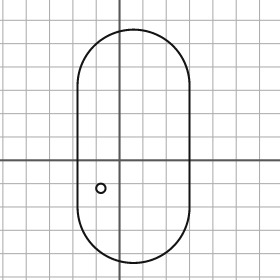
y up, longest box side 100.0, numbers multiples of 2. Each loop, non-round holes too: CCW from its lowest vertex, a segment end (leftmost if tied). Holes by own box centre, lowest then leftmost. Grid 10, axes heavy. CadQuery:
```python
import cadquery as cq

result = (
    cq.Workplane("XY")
    .moveTo(-18.0, -20.0)
    .threePointArc((6.0, -44.0), (30.0, -20.0))
    .lineTo(30.0, 32.0)
    .threePointArc((6.0, 56.0), (-18.0, 32.0))
    .close()
    .moveTo(-8.0, -12.0)
    .circle(2.0)
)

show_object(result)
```